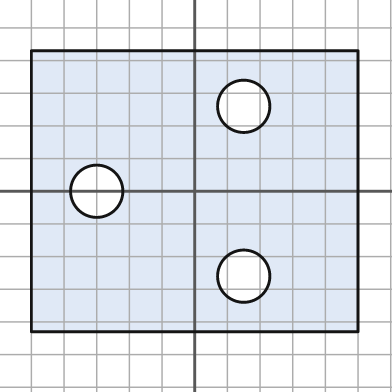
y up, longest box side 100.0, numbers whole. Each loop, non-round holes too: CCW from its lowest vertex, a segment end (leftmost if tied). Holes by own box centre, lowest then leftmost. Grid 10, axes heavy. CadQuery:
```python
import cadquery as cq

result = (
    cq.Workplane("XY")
    .moveTo(-50.0, -43.0)
    .lineTo(50.0, -43.0)
    .lineTo(50.0, 43.0)
    .lineTo(-50.0, 43.0)
    .close()
    .moveTo(15.0, -26.0)
    .circle(8.0)
    .moveTo(-30.0, 0.0)
    .circle(8.0)
    .moveTo(15.0, 26.0)
    .circle(8.0)
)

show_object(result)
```